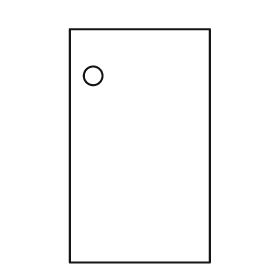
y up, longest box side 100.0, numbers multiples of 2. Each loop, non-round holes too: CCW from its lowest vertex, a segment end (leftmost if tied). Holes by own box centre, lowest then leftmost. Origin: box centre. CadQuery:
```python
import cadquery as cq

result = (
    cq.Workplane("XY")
    .moveTo(-30.0, -50.0)
    .lineTo(30.0, -50.0)
    .lineTo(30.0, 50.0)
    .lineTo(-30.0, 50.0)
    .close()
    .moveTo(-20.0, 30.0)
    .circle(4.0)
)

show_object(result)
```